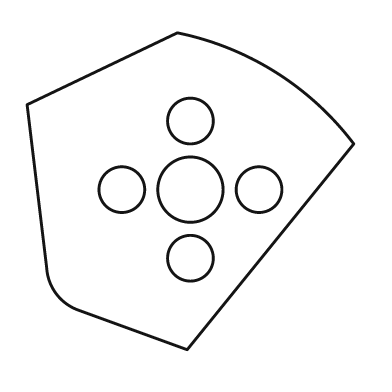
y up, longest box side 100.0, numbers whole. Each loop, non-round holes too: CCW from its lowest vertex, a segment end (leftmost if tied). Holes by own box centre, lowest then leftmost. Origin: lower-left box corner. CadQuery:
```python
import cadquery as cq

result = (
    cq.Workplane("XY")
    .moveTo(49.0, 0.0)
    .lineTo(100.0, 63.0)
    .threePointArc((76.0, 85.0), (46.0, 97.0))
    .lineTo(0.0, 75.0)
    .lineTo(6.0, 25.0)
    .threePointArc((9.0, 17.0), (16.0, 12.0))
    .close()
    .moveTo(50.0, 28.0)
    .circle(7.0)
    .moveTo(29.0, 49.0)
    .circle(7.0)
    .moveTo(50.0, 49.0)
    .circle(10.0)
    .moveTo(71.0, 49.0)
    .circle(7.0)
    .moveTo(50.0, 70.0)
    .circle(7.0)
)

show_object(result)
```